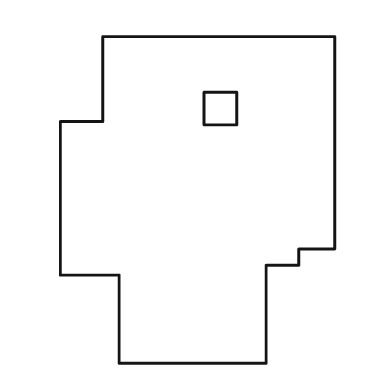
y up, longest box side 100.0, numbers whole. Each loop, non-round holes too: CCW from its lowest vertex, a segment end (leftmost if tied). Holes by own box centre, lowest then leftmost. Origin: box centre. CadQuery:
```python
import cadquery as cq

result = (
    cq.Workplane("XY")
    .moveTo(-24.0, -50.0)
    .lineTo(21.0, -50.0)
    .lineTo(21.0, -20.0)
    .lineTo(31.0, -20.0)
    .lineTo(31.0, -15.0)
    .lineTo(42.0, -15.0)
    .lineTo(42.0, 50.0)
    .lineTo(-29.0, 50.0)
    .lineTo(-29.0, 24.0)
    .lineTo(-42.0, 24.0)
    .lineTo(-42.0, -23.0)
    .lineTo(-24.0, -23.0)
    .close()
    .moveTo(2.0, 23.0)
    .lineTo(12.0, 23.0)
    .lineTo(12.0, 33.0)
    .lineTo(2.0, 33.0)
    .close()
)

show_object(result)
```